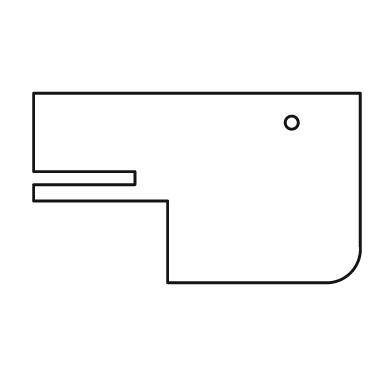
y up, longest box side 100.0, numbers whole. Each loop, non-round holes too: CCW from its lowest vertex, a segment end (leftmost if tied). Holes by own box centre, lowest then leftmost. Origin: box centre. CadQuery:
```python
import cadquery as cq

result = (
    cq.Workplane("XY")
    .moveTo(-9.0, -29.0)
    .lineTo(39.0, -29.0)
    .threePointArc((47.0, -26.0), (50.0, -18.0))
    .lineTo(50.0, 29.0)
    .lineTo(-50.0, 29.0)
    .lineTo(-50.0, 5.0)
    .lineTo(-19.0, 5.0)
    .lineTo(-19.0, 1.0)
    .lineTo(-50.0, 1.0)
    .lineTo(-50.0, -4.0)
    .lineTo(-9.0, -4.0)
    .close()
    .moveTo(29.0, 20.0)
    .circle(2.0)
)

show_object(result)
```